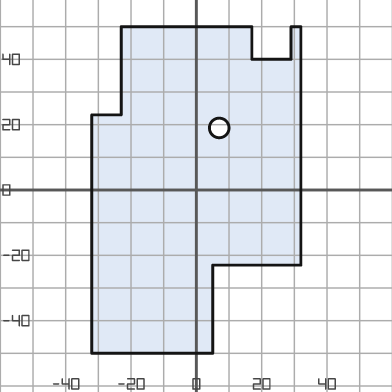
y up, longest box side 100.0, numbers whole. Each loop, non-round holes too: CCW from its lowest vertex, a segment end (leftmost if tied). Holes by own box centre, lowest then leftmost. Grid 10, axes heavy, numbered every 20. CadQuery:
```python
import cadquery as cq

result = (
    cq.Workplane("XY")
    .moveTo(-32.0, -50.0)
    .lineTo(5.0, -50.0)
    .lineTo(5.0, -23.0)
    .lineTo(32.0, -23.0)
    .lineTo(32.0, 50.0)
    .lineTo(29.0, 50.0)
    .lineTo(29.0, 40.0)
    .lineTo(17.0, 40.0)
    .lineTo(17.0, 50.0)
    .lineTo(-23.0, 50.0)
    .lineTo(-23.0, 23.0)
    .lineTo(-32.0, 23.0)
    .close()
    .moveTo(7.0, 19.0)
    .circle(3.0)
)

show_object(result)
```